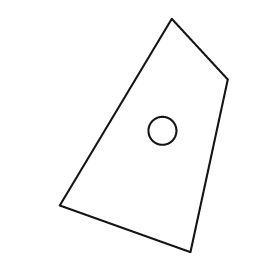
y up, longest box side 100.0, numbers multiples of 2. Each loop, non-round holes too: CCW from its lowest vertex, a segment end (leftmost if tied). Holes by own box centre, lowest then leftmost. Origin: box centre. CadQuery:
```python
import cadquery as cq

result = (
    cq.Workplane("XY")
    .moveTo(20.0, -50.0)
    .lineTo(36.0, 24.0)
    .lineTo(12.0, 50.0)
    .lineTo(-36.0, -30.0)
    .close()
    .moveTo(8.0, 2.0)
    .circle(6.0)
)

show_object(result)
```